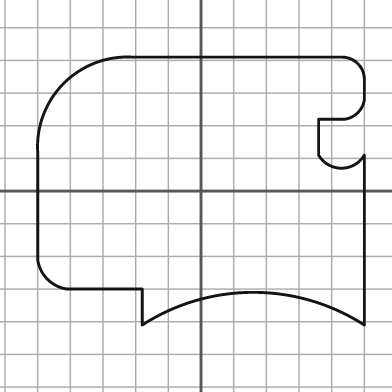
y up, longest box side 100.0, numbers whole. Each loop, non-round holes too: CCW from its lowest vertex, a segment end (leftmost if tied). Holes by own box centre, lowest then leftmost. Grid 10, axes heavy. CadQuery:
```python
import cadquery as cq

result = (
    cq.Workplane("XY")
    .moveTo(-18.0, -41.0)
    .threePointArc((16.0, -31.0), (50.0, -41.0))
    .lineTo(50.0, 11.0)
    .threePointArc((43.0, 7.0), (36.0, 11.0))
    .lineTo(36.0, 22.0)
    .lineTo(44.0, 22.0)
    .threePointArc((48.0, 24.0), (50.0, 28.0))
    .lineTo(50.0, 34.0)
    .threePointArc((48.0, 39.0), (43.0, 41.0))
    .lineTo(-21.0, 41.0)
    .threePointArc((-42.0, 33.0), (-50.0, 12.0))
    .lineTo(-50.0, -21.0)
    .threePointArc((-47.0, -27.0), (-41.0, -30.0))
    .lineTo(-18.0, -30.0)
    .close()
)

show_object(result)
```